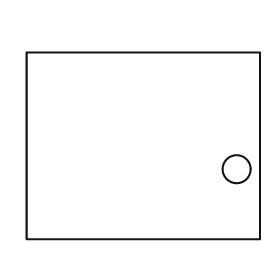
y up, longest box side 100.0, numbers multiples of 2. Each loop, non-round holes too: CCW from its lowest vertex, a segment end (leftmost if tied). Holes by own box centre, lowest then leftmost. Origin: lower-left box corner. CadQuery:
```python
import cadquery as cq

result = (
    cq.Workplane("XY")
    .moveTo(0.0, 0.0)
    .lineTo(100.0, 0.0)
    .lineTo(100.0, 80.0)
    .lineTo(0.0, 80.0)
    .close()
    .moveTo(90.0, 30.0)
    .circle(6.0)
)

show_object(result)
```